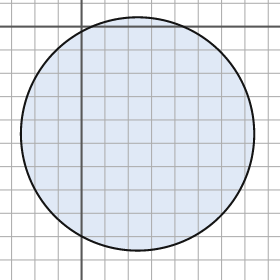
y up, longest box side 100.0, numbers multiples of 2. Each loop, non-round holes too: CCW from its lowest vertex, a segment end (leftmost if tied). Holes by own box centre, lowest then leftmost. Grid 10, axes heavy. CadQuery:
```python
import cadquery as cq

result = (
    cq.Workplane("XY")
    .moveTo(24.0, -46.0)
    .circle(50.0)
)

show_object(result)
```